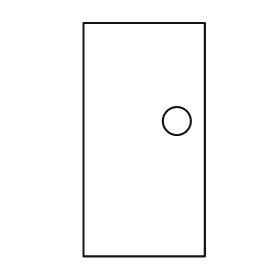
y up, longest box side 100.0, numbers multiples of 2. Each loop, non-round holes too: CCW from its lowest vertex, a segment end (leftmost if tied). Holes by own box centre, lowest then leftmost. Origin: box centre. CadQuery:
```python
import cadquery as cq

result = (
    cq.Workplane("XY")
    .moveTo(-26.0, -50.0)
    .lineTo(26.0, -50.0)
    .lineTo(26.0, 50.0)
    .lineTo(-26.0, 50.0)
    .close()
    .moveTo(14.0, 8.0)
    .circle(6.0)
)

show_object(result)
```